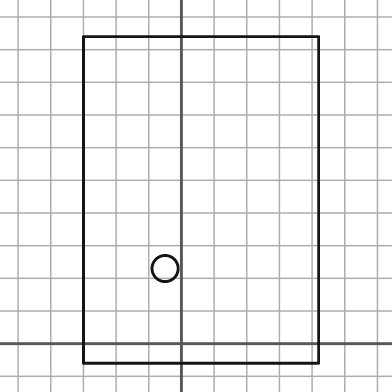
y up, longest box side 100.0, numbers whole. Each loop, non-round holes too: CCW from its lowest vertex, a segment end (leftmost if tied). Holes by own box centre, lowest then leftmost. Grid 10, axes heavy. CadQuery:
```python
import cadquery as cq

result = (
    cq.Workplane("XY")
    .moveTo(-30.0, -6.0)
    .lineTo(42.0, -6.0)
    .lineTo(42.0, 94.0)
    .lineTo(-30.0, 94.0)
    .close()
    .moveTo(-5.0, 23.0)
    .circle(4.0)
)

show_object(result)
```